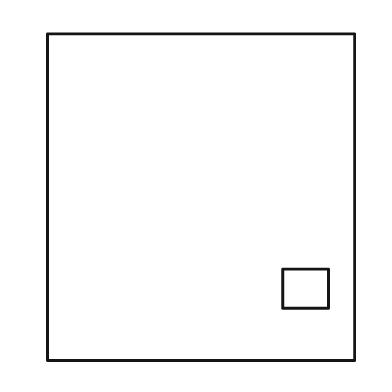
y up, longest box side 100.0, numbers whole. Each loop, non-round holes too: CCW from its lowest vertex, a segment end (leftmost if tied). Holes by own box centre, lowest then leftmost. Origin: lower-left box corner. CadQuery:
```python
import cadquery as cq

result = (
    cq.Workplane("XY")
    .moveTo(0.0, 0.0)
    .lineTo(94.0, 0.0)
    .lineTo(94.0, 100.0)
    .lineTo(0.0, 100.0)
    .close()
    .moveTo(72.0, 16.0)
    .lineTo(86.0, 16.0)
    .lineTo(86.0, 28.0)
    .lineTo(72.0, 28.0)
    .close()
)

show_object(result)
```